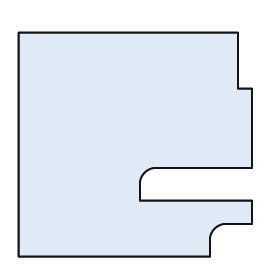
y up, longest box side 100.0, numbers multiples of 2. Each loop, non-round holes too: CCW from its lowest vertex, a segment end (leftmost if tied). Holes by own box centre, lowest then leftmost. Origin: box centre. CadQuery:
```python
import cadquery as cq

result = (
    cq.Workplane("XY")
    .moveTo(-50.0, -48.0)
    .lineTo(32.0, -48.0)
    .lineTo(32.0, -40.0)
    .threePointArc((34.0, -36.0), (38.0, -34.0))
    .lineTo(50.0, -34.0)
    .lineTo(50.0, -24.0)
    .lineTo(2.0, -24.0)
    .lineTo(2.0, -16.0)
    .threePointArc((4.0, -12.0), (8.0, -10.0))
    .lineTo(50.0, -10.0)
    .lineTo(50.0, 24.0)
    .lineTo(44.0, 24.0)
    .lineTo(44.0, 48.0)
    .lineTo(-50.0, 48.0)
    .close()
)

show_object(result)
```